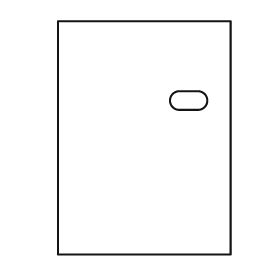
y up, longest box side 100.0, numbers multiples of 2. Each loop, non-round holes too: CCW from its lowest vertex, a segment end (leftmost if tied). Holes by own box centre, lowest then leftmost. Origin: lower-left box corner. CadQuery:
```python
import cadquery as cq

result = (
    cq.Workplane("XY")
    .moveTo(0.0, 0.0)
    .lineTo(74.0, 0.0)
    .lineTo(74.0, 100.0)
    .lineTo(0.0, 100.0)
    .close()
    .moveTo(52.0, 62.0)
    .lineTo(60.0, 62.0)
    .threePointArc((64.0, 66.0), (60.0, 70.0))
    .lineTo(52.0, 70.0)
    .threePointArc((48.0, 66.0), (52.0, 62.0))
    .close()
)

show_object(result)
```